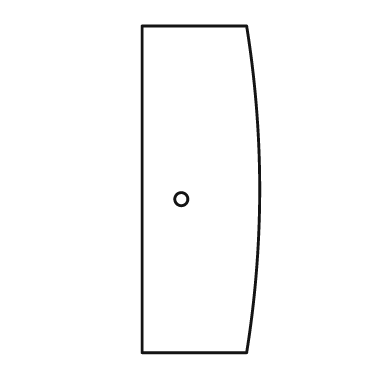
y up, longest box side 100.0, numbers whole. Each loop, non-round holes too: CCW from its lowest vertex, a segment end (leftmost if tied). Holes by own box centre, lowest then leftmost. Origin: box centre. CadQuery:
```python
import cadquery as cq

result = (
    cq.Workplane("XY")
    .moveTo(-18.0, -50.0)
    .lineTo(14.0, -50.0)
    .threePointArc((18.0, 0.0), (14.0, 50.0))
    .lineTo(-18.0, 50.0)
    .close()
    .moveTo(-6.0, -3.0)
    .circle(2.0)
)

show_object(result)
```